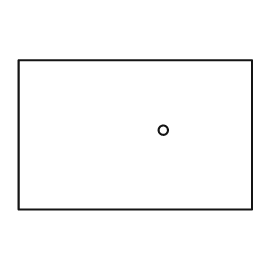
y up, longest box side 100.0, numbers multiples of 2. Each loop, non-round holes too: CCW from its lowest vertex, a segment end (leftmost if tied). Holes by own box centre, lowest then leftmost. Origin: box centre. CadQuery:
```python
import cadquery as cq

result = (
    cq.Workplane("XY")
    .moveTo(-50.0, -32.0)
    .lineTo(50.0, -32.0)
    .lineTo(50.0, 32.0)
    .lineTo(-50.0, 32.0)
    .close()
    .moveTo(12.0, 2.0)
    .circle(2.0)
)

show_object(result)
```